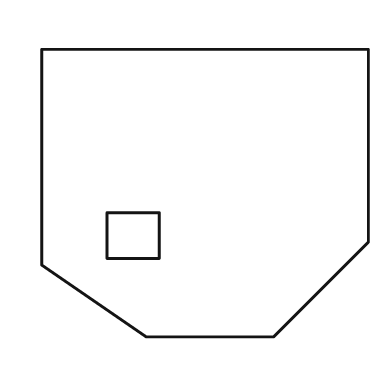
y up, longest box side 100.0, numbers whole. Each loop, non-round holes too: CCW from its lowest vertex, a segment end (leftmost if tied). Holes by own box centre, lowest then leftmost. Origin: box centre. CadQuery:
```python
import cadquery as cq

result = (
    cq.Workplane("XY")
    .moveTo(-18.0, -44.0)
    .lineTo(21.0, -44.0)
    .lineTo(50.0, -15.0)
    .lineTo(50.0, 44.0)
    .lineTo(-50.0, 44.0)
    .lineTo(-50.0, -22.0)
    .close()
    .moveTo(-30.0, -20.0)
    .lineTo(-14.0, -20.0)
    .lineTo(-14.0, -6.0)
    .lineTo(-30.0, -6.0)
    .close()
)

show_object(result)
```